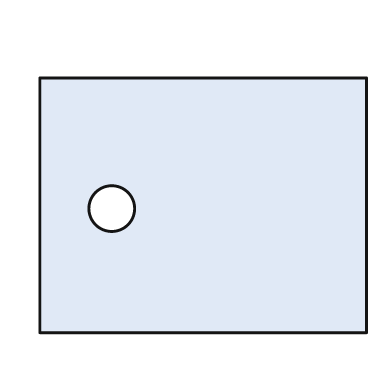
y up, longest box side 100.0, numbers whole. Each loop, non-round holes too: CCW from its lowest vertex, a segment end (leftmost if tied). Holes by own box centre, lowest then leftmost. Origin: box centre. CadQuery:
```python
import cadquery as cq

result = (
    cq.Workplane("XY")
    .moveTo(-50.0, -39.0)
    .lineTo(50.0, -39.0)
    .lineTo(50.0, 39.0)
    .lineTo(-50.0, 39.0)
    .close()
    .moveTo(-28.0, -1.0)
    .circle(7.0)
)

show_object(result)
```